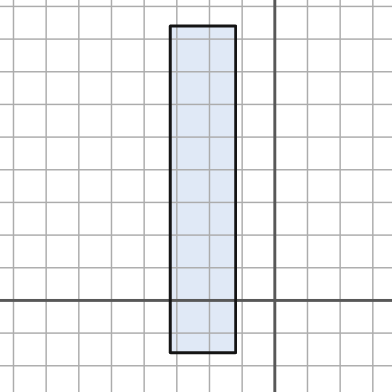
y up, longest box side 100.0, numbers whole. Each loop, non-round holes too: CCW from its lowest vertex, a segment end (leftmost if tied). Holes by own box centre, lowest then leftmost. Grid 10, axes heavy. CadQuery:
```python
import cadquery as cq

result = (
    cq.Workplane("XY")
    .moveTo(-32.0, -16.0)
    .lineTo(-12.0, -16.0)
    .lineTo(-12.0, 84.0)
    .lineTo(-32.0, 84.0)
    .close()
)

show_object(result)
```